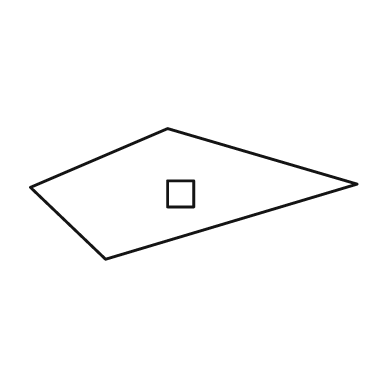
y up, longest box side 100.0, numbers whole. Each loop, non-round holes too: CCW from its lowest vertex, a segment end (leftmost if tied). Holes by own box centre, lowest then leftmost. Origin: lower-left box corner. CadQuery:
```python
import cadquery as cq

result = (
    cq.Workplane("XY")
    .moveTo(23.0, 0.0)
    .lineTo(100.0, 23.0)
    .lineTo(42.0, 40.0)
    .lineTo(0.0, 22.0)
    .close()
    .moveTo(42.0, 16.0)
    .lineTo(50.0, 16.0)
    .lineTo(50.0, 24.0)
    .lineTo(42.0, 24.0)
    .close()
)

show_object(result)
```